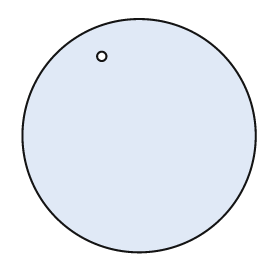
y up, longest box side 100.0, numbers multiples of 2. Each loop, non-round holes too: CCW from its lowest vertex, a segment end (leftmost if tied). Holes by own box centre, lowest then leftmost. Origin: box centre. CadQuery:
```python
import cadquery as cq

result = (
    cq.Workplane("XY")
    .moveTo(0.0, 0.0)
    .circle(50.0)
    .moveTo(-16.0, 34.0)
    .circle(2.0)
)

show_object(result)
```